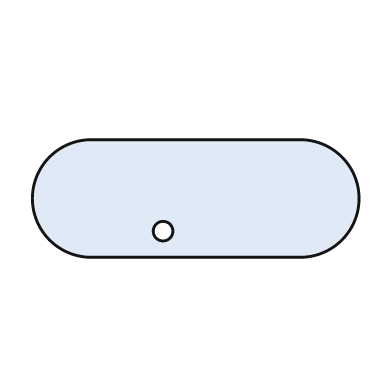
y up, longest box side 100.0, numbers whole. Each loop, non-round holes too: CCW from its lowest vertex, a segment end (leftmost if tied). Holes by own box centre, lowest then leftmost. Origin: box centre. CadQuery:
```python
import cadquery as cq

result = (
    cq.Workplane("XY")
    .moveTo(-32.0, -18.0)
    .lineTo(32.0, -18.0)
    .threePointArc((50.0, 0.0), (32.0, 18.0))
    .lineTo(-32.0, 18.0)
    .threePointArc((-50.0, 0.0), (-32.0, -18.0))
    .close()
    .moveTo(-10.0, -10.0)
    .circle(3.0)
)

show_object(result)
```